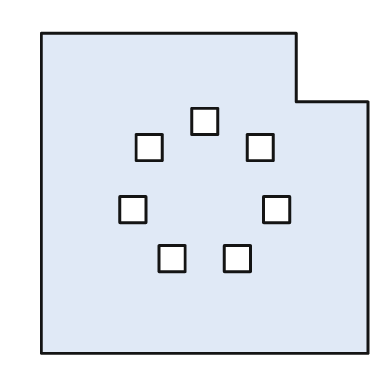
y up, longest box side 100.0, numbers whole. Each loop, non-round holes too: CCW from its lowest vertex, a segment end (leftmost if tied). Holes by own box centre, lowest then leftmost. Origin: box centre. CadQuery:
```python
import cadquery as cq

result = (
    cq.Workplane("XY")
    .moveTo(-50.0, -49.0)
    .lineTo(50.0, -49.0)
    .lineTo(50.0, 28.0)
    .lineTo(28.0, 28.0)
    .lineTo(28.0, 49.0)
    .lineTo(-50.0, 49.0)
    .close()
    .moveTo(-14.0, -24.0)
    .lineTo(-6.0, -24.0)
    .lineTo(-6.0, -16.0)
    .lineTo(-14.0, -16.0)
    .close()
    .moveTo(6.0, -24.0)
    .lineTo(14.0, -24.0)
    .lineTo(14.0, -16.0)
    .lineTo(6.0, -16.0)
    .close()
    .moveTo(-26.0, -9.0)
    .lineTo(-18.0, -9.0)
    .lineTo(-18.0, -1.0)
    .lineTo(-26.0, -1.0)
    .close()
    .moveTo(18.0, -9.0)
    .lineTo(26.0, -9.0)
    .lineTo(26.0, -1.0)
    .lineTo(18.0, -1.0)
    .close()
    .moveTo(-21.0, 10.0)
    .lineTo(-13.0, 10.0)
    .lineTo(-13.0, 18.0)
    .lineTo(-21.0, 18.0)
    .close()
    .moveTo(13.0, 10.0)
    .lineTo(21.0, 10.0)
    .lineTo(21.0, 18.0)
    .lineTo(13.0, 18.0)
    .close()
    .moveTo(-4.0, 18.0)
    .lineTo(4.0, 18.0)
    .lineTo(4.0, 26.0)
    .lineTo(-4.0, 26.0)
    .close()
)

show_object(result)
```